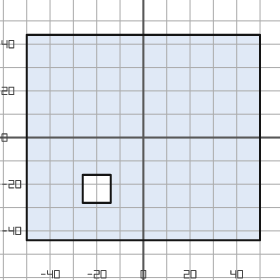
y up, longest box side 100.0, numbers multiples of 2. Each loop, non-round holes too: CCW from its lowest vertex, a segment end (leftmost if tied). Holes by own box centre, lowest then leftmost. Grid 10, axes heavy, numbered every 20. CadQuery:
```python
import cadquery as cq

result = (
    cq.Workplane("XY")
    .moveTo(-50.0, -44.0)
    .lineTo(50.0, -44.0)
    .lineTo(50.0, 44.0)
    .lineTo(-50.0, 44.0)
    .close()
    .moveTo(-26.0, -28.0)
    .lineTo(-14.0, -28.0)
    .lineTo(-14.0, -16.0)
    .lineTo(-26.0, -16.0)
    .close()
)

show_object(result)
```